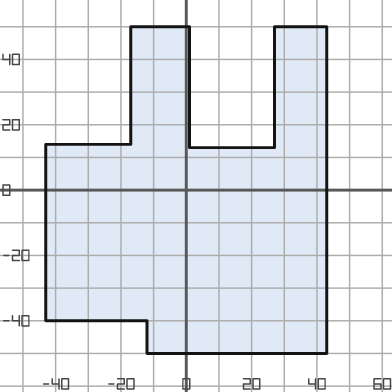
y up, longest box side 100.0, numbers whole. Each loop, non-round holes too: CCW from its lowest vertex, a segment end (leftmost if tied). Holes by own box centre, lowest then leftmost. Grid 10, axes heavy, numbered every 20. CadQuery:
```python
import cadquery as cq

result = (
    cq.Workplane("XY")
    .moveTo(-12.0, -50.0)
    .lineTo(43.0, -50.0)
    .lineTo(43.0, 50.0)
    .lineTo(27.0, 50.0)
    .lineTo(27.0, 13.0)
    .lineTo(1.0, 13.0)
    .lineTo(1.0, 50.0)
    .lineTo(-17.0, 50.0)
    .lineTo(-17.0, 14.0)
    .lineTo(-43.0, 14.0)
    .lineTo(-43.0, -40.0)
    .lineTo(-12.0, -40.0)
    .close()
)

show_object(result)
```